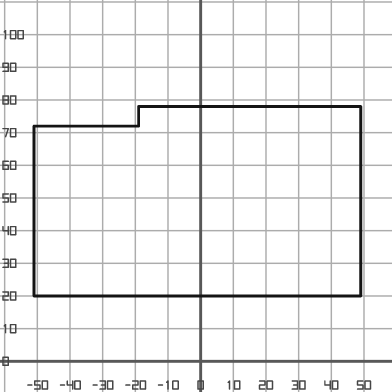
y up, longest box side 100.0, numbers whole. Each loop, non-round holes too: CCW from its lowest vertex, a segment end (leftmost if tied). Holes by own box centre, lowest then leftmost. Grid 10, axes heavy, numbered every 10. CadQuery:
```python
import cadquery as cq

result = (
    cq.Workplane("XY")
    .moveTo(-51.0, 20.0)
    .lineTo(49.0, 20.0)
    .lineTo(49.0, 78.0)
    .lineTo(-19.0, 78.0)
    .lineTo(-19.0, 72.0)
    .lineTo(-51.0, 72.0)
    .close()
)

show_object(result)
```